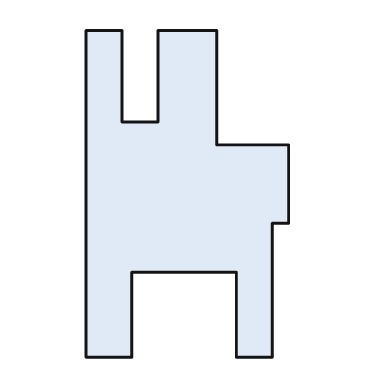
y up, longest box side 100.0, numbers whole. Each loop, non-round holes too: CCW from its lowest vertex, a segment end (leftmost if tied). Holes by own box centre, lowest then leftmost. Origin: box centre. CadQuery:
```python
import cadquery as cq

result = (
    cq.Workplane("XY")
    .moveTo(-31.0, -50.0)
    .lineTo(-17.0, -50.0)
    .lineTo(-17.0, -24.0)
    .lineTo(15.0, -24.0)
    .lineTo(15.0, -50.0)
    .lineTo(26.0, -50.0)
    .lineTo(26.0, -9.0)
    .lineTo(31.0, -9.0)
    .lineTo(31.0, 15.0)
    .lineTo(9.0, 15.0)
    .lineTo(9.0, 50.0)
    .lineTo(-9.0, 50.0)
    .lineTo(-9.0, 22.0)
    .lineTo(-20.0, 22.0)
    .lineTo(-20.0, 50.0)
    .lineTo(-31.0, 50.0)
    .close()
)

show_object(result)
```